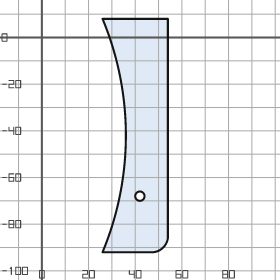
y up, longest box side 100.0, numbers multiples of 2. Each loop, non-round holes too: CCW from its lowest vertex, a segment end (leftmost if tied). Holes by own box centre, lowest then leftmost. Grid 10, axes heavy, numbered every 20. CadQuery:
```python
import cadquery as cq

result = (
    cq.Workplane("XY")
    .moveTo(26.0, -92.0)
    .lineTo(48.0, -92.0)
    .threePointArc((52.0, -90.0), (54.0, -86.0))
    .lineTo(54.0, 8.0)
    .lineTo(26.0, 8.0)
    .threePointArc((36.0, -42.0), (26.0, -92.0))
    .close()
    .moveTo(42.0, -68.0)
    .circle(2.0)
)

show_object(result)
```